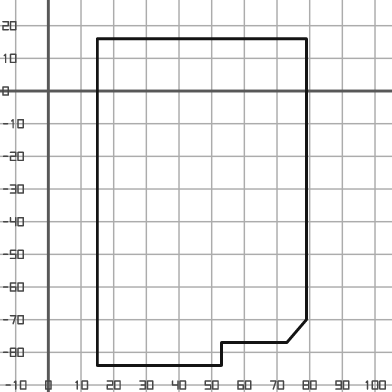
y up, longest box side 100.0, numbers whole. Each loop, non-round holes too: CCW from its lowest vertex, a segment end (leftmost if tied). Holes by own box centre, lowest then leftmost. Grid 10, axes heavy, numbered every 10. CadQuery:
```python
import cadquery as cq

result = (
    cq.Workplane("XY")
    .moveTo(15.0, -84.0)
    .lineTo(53.0, -84.0)
    .lineTo(53.0, -77.0)
    .lineTo(73.0, -77.0)
    .lineTo(79.0, -70.0)
    .lineTo(79.0, 16.0)
    .lineTo(15.0, 16.0)
    .close()
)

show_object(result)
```